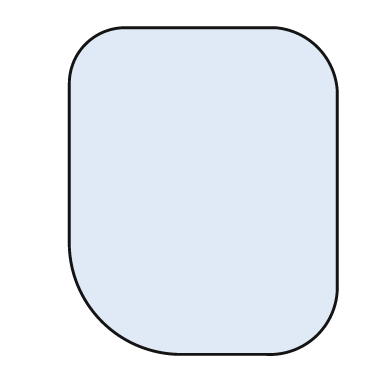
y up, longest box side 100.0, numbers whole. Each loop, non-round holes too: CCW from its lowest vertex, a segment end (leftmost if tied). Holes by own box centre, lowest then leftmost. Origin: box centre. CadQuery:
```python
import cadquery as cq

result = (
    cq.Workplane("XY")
    .moveTo(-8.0, -50.0)
    .lineTo(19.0, -50.0)
    .threePointArc((35.0, -44.0), (41.0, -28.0))
    .lineTo(41.0, 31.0)
    .threePointArc((35.0, 44.0), (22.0, 50.0))
    .lineTo(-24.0, 50.0)
    .threePointArc((-36.0, 45.0), (-41.0, 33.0))
    .lineTo(-41.0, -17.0)
    .threePointArc((-31.0, -40.0), (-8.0, -50.0))
    .close()
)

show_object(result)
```